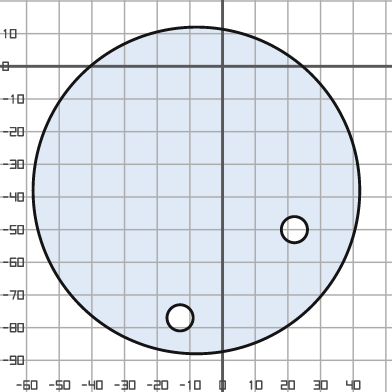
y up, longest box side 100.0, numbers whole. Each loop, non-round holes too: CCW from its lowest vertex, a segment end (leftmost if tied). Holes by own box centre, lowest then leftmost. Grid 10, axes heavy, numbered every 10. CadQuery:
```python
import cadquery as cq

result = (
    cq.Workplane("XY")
    .moveTo(-8.0, -38.0)
    .circle(50.0)
    .moveTo(-13.0, -77.0)
    .circle(4.0)
    .moveTo(22.0, -50.0)
    .circle(4.0)
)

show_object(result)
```